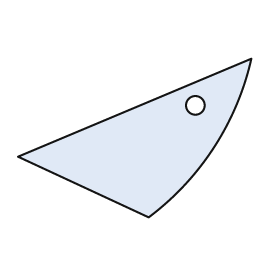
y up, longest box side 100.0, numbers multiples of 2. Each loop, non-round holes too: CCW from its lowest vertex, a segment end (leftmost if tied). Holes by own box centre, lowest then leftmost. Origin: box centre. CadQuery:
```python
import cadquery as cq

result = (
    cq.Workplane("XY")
    .moveTo(6.0, -34.0)
    .threePointArc((34.0, -4.0), (50.0, 34.0))
    .lineTo(-50.0, -8.0)
    .close()
    .moveTo(26.0, 14.0)
    .circle(4.0)
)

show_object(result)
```